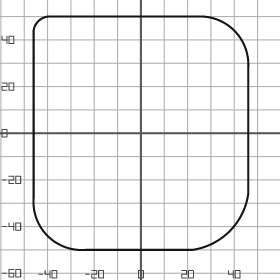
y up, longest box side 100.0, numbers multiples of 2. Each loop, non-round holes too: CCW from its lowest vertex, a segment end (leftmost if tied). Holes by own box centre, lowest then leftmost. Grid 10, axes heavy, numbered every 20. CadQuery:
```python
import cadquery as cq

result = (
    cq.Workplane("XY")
    .moveTo(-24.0, -50.0)
    .lineTo(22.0, -50.0)
    .threePointArc((38.0, -42.0), (46.0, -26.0))
    .lineTo(46.0, 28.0)
    .threePointArc((40.0, 44.0), (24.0, 50.0))
    .lineTo(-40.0, 50.0)
    .threePointArc((-44.0, 48.0), (-46.0, 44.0))
    .lineTo(-46.0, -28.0)
    .threePointArc((-40.0, -44.0), (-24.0, -50.0))
    .close()
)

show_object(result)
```